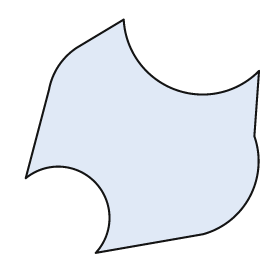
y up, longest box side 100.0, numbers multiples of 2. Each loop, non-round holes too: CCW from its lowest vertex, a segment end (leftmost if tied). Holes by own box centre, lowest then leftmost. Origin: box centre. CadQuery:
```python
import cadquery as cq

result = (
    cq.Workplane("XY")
    .moveTo(-20.0, -50.0)
    .lineTo(26.0, -42.0)
    .threePointArc((46.0, -26.0), (48.0, 0.0))
    .lineTo(50.0, 28.0)
    .threePointArc((14.0, 20.0), (-8.0, 50.0))
    .lineTo(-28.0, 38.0)
    .threePointArc((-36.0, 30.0), (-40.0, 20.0))
    .lineTo(-50.0, -18.0)
    .threePointArc((-20.0, -20.0), (-20.0, -50.0))
    .close()
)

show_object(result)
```